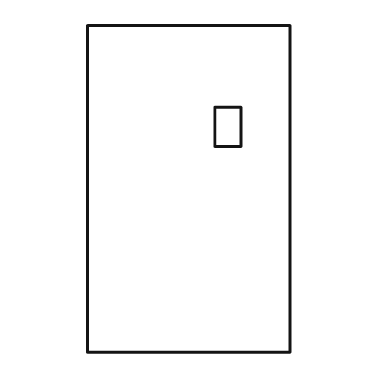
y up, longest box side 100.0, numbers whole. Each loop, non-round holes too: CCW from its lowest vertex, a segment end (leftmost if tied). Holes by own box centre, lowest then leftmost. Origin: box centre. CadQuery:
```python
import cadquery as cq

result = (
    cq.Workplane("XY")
    .moveTo(-31.0, -50.0)
    .lineTo(31.0, -50.0)
    .lineTo(31.0, 50.0)
    .lineTo(-31.0, 50.0)
    .close()
    .moveTo(8.0, 13.0)
    .lineTo(16.0, 13.0)
    .lineTo(16.0, 25.0)
    .lineTo(8.0, 25.0)
    .close()
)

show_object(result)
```